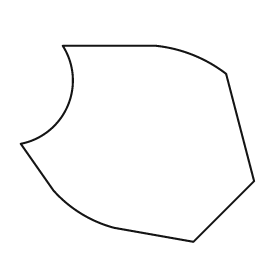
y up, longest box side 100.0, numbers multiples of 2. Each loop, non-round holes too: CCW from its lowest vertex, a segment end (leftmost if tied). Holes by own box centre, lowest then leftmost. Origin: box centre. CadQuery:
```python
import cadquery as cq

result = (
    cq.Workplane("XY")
    .moveTo(24.0, -42.0)
    .lineTo(50.0, -16.0)
    .lineTo(38.0, 30.0)
    .threePointArc((24.0, 38.0), (8.0, 42.0))
    .lineTo(-32.0, 42.0)
    .threePointArc((-30.0, 16.0), (-50.0, 0.0))
    .lineTo(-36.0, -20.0)
    .threePointArc((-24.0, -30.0), (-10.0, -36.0))
    .close()
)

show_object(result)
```